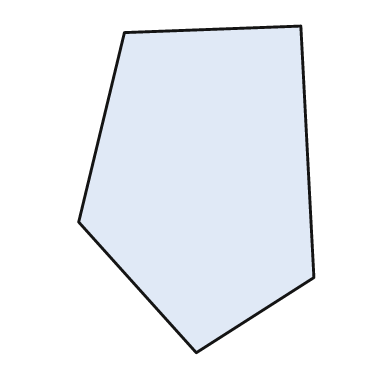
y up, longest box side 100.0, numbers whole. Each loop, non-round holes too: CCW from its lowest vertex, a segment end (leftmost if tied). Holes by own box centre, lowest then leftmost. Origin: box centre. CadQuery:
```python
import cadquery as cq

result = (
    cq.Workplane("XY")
    .moveTo(0.0, -50.0)
    .lineTo(36.0, -27.0)
    .lineTo(32.0, 50.0)
    .lineTo(-22.0, 48.0)
    .lineTo(-36.0, -10.0)
    .close()
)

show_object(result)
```